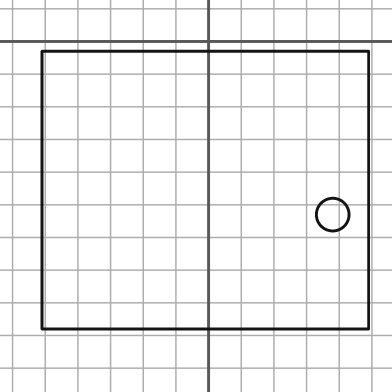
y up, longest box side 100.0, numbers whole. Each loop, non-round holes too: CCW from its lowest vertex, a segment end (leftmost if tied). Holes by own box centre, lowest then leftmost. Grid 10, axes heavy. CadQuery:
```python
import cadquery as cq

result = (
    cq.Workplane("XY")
    .moveTo(-51.0, -88.0)
    .lineTo(49.0, -88.0)
    .lineTo(49.0, -3.0)
    .lineTo(-51.0, -3.0)
    .close()
    .moveTo(38.0, -53.0)
    .circle(5.0)
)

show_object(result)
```